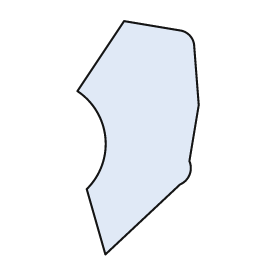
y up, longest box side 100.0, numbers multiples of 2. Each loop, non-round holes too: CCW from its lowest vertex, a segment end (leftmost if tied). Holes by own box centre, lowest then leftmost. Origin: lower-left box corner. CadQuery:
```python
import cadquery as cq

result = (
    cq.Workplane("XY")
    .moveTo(12.0, 0.0)
    .lineTo(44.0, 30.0)
    .threePointArc((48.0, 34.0), (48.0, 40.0))
    .lineTo(52.0, 64.0)
    .lineTo(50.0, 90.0)
    .threePointArc((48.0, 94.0), (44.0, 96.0))
    .lineTo(20.0, 100.0)
    .lineTo(0.0, 70.0)
    .threePointArc((12.0, 50.0), (4.0, 28.0))
    .close()
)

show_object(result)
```